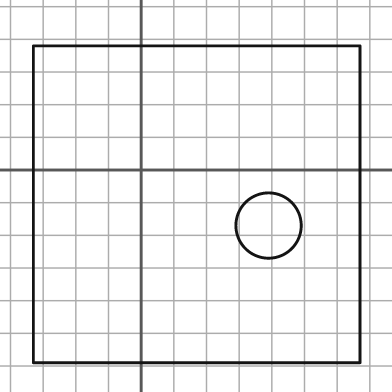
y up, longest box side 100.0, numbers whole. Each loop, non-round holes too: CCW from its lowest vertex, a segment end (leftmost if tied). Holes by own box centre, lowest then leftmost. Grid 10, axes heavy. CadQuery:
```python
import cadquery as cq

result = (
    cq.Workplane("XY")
    .moveTo(-33.0, -59.0)
    .lineTo(67.0, -59.0)
    .lineTo(67.0, 38.0)
    .lineTo(-33.0, 38.0)
    .close()
    .moveTo(39.0, -17.0)
    .circle(10.0)
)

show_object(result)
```